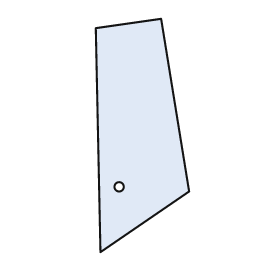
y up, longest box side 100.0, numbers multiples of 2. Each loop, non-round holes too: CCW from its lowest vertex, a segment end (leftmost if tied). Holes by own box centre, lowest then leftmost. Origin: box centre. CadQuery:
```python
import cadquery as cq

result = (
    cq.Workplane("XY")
    .moveTo(-18.0, -50.0)
    .lineTo(20.0, -24.0)
    .lineTo(8.0, 50.0)
    .lineTo(-20.0, 46.0)
    .close()
    .moveTo(-10.0, -22.0)
    .circle(2.0)
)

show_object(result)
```